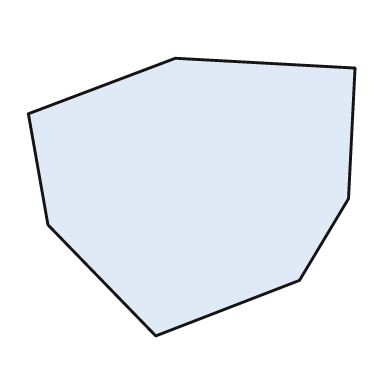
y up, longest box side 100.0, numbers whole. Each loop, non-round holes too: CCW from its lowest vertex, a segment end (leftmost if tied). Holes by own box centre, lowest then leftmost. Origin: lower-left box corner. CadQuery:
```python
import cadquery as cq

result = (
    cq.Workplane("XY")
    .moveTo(39.0, 0.0)
    .lineTo(83.0, 17.0)
    .lineTo(98.0, 42.0)
    .lineTo(100.0, 82.0)
    .lineTo(45.0, 85.0)
    .lineTo(0.0, 68.0)
    .lineTo(6.0, 34.0)
    .close()
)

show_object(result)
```